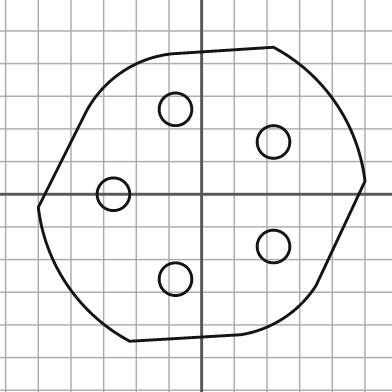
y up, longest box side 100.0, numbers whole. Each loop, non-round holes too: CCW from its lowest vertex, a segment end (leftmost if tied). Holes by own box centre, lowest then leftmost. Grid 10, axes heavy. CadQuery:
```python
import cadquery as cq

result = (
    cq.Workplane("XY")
    .moveTo(-22.0, -45.0)
    .lineTo(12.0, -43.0)
    .threePointArc((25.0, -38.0), (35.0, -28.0))
    .lineTo(50.0, 4.0)
    .threePointArc((41.0, 28.0), (22.0, 45.0))
    .lineTo(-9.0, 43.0)
    .threePointArc((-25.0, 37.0), (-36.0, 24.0))
    .lineTo(-50.0, -4.0)
    .threePointArc((-41.0, -28.0), (-22.0, -45.0))
    .close()
    .moveTo(-8.0, -26.0)
    .circle(5.0)
    .moveTo(22.0, -16.0)
    .circle(5.0)
    .moveTo(-27.0, 0.0)
    .circle(5.0)
    .moveTo(22.0, 16.0)
    .circle(5.0)
    .moveTo(-8.0, 26.0)
    .circle(5.0)
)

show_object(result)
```